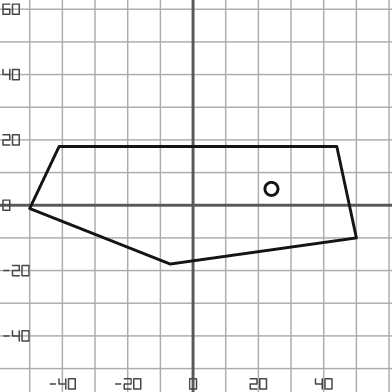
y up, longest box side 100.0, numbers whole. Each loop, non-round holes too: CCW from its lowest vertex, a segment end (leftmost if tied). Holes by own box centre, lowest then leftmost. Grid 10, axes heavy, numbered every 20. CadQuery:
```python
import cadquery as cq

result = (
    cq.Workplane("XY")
    .moveTo(-7.0, -18.0)
    .lineTo(50.0, -10.0)
    .lineTo(44.0, 18.0)
    .lineTo(-41.0, 18.0)
    .lineTo(-50.0, -1.0)
    .close()
    .moveTo(24.0, 5.0)
    .circle(2.0)
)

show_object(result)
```